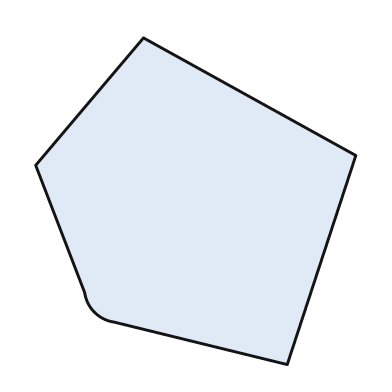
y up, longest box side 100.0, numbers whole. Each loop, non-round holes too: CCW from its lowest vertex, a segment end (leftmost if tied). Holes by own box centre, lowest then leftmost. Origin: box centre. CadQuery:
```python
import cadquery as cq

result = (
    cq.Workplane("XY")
    .moveTo(28.0, -50.0)
    .lineTo(49.0, 14.0)
    .lineTo(-16.0, 50.0)
    .lineTo(-49.0, 11.0)
    .lineTo(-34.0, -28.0)
    .threePointArc((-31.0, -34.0), (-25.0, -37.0))
    .close()
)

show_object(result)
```